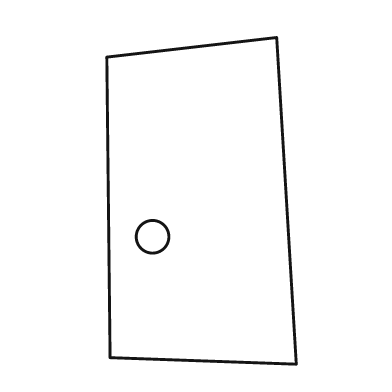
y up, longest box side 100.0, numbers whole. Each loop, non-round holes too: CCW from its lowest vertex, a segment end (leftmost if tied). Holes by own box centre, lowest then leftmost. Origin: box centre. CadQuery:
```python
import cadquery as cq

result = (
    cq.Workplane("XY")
    .moveTo(29.0, -50.0)
    .lineTo(23.0, 50.0)
    .lineTo(-29.0, 44.0)
    .lineTo(-28.0, -48.0)
    .close()
    .moveTo(-15.0, -11.0)
    .circle(5.0)
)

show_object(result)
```